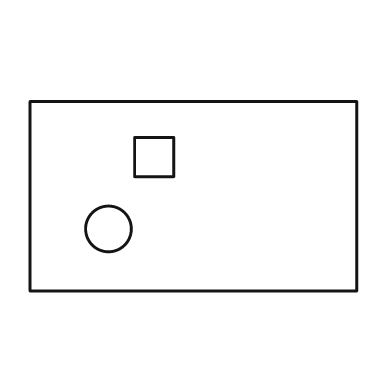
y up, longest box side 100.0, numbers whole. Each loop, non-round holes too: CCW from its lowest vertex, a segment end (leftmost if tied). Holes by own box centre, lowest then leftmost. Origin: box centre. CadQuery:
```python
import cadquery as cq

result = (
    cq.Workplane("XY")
    .moveTo(-50.0, -29.0)
    .lineTo(50.0, -29.0)
    .lineTo(50.0, 29.0)
    .lineTo(-50.0, 29.0)
    .close()
    .moveTo(-26.0, -10.0)
    .circle(7.0)
    .moveTo(-18.0, 6.0)
    .lineTo(-6.0, 6.0)
    .lineTo(-6.0, 18.0)
    .lineTo(-18.0, 18.0)
    .close()
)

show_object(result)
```